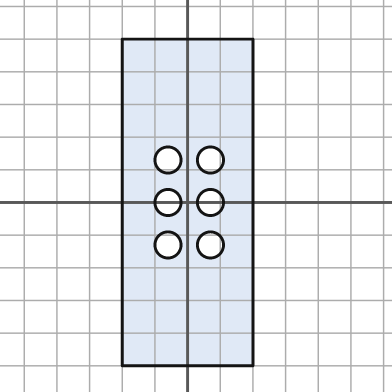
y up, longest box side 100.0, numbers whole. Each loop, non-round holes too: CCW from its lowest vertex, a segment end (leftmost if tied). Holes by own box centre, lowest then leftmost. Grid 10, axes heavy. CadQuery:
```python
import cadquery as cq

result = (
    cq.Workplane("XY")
    .moveTo(-20.0, -50.0)
    .lineTo(20.0, -50.0)
    .lineTo(20.0, 50.0)
    .lineTo(-20.0, 50.0)
    .close()
    .moveTo(-6.0, -13.0)
    .circle(4.0)
    .moveTo(7.0, -13.0)
    .circle(4.0)
    .moveTo(-6.0, 0.0)
    .circle(4.0)
    .moveTo(7.0, 0.0)
    .circle(4.0)
    .moveTo(-6.0, 13.0)
    .circle(4.0)
    .moveTo(7.0, 13.0)
    .circle(4.0)
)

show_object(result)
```